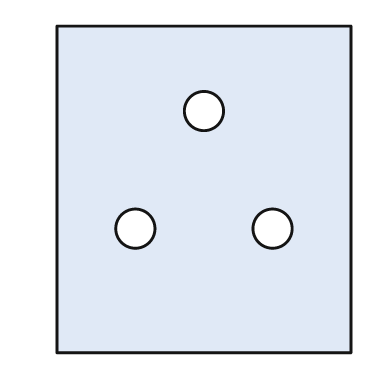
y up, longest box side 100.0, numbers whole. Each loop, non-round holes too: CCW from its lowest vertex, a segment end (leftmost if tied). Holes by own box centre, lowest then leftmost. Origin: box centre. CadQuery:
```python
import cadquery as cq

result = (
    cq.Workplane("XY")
    .moveTo(-45.0, -50.0)
    .lineTo(45.0, -50.0)
    .lineTo(45.0, 50.0)
    .lineTo(-45.0, 50.0)
    .close()
    .moveTo(-21.0, -12.0)
    .circle(6.0)
    .moveTo(21.0, -12.0)
    .circle(6.0)
    .moveTo(0.0, 24.0)
    .circle(6.0)
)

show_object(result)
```